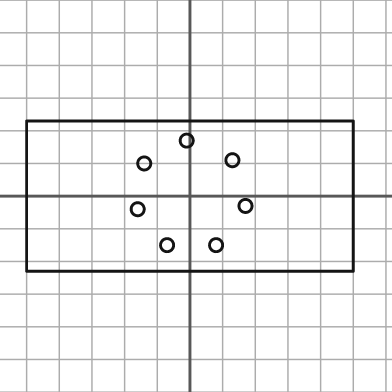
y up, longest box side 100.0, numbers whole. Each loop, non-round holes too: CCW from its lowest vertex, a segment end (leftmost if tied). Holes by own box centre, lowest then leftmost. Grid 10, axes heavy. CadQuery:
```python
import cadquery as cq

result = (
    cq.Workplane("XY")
    .moveTo(-50.0, -23.0)
    .lineTo(50.0, -23.0)
    .lineTo(50.0, 23.0)
    .lineTo(-50.0, 23.0)
    .close()
    .moveTo(-7.0, -15.0)
    .circle(2.0)
    .moveTo(8.0, -15.0)
    .circle(2.0)
    .moveTo(-16.0, -4.0)
    .circle(2.0)
    .moveTo(17.0, -3.0)
    .circle(2.0)
    .moveTo(-14.0, 10.0)
    .circle(2.0)
    .moveTo(13.0, 11.0)
    .circle(2.0)
    .moveTo(-1.0, 17.0)
    .circle(2.0)
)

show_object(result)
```